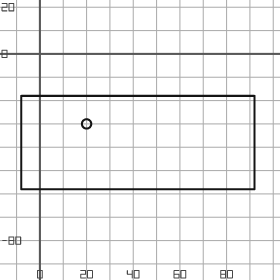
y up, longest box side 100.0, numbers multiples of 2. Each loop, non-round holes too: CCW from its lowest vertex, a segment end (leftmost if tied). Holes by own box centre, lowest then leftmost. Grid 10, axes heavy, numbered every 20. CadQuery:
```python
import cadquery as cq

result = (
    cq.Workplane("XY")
    .moveTo(-8.0, -58.0)
    .lineTo(92.0, -58.0)
    .lineTo(92.0, -18.0)
    .lineTo(-8.0, -18.0)
    .close()
    .moveTo(20.0, -30.0)
    .circle(2.0)
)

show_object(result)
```